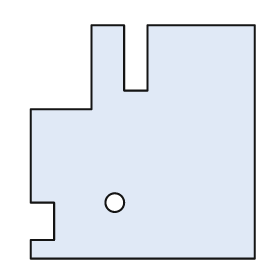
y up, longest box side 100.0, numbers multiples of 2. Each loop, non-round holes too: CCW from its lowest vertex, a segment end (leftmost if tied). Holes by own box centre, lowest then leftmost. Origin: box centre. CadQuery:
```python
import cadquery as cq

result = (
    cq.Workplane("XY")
    .moveTo(-48.0, -50.0)
    .lineTo(48.0, -50.0)
    .lineTo(48.0, 50.0)
    .lineTo(2.0, 50.0)
    .lineTo(2.0, 22.0)
    .lineTo(-8.0, 22.0)
    .lineTo(-8.0, 50.0)
    .lineTo(-22.0, 50.0)
    .lineTo(-22.0, 14.0)
    .lineTo(-48.0, 14.0)
    .lineTo(-48.0, -26.0)
    .lineTo(-38.0, -26.0)
    .lineTo(-38.0, -42.0)
    .lineTo(-48.0, -42.0)
    .close()
    .moveTo(-12.0, -26.0)
    .circle(4.0)
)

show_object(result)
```